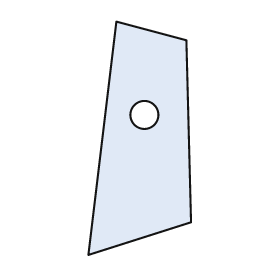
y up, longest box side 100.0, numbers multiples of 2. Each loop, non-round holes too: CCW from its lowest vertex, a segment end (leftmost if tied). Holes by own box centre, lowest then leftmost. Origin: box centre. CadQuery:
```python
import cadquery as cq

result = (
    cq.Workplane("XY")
    .moveTo(-22.0, -50.0)
    .lineTo(22.0, -36.0)
    .lineTo(20.0, 42.0)
    .lineTo(-10.0, 50.0)
    .close()
    .moveTo(2.0, 10.0)
    .circle(6.0)
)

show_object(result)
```